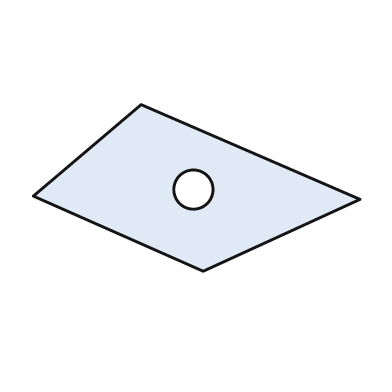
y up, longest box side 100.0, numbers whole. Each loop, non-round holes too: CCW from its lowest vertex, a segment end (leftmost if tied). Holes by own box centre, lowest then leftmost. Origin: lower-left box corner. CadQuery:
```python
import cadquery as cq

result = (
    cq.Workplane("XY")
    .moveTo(52.0, 0.0)
    .lineTo(100.0, 22.0)
    .lineTo(33.0, 51.0)
    .lineTo(0.0, 23.0)
    .close()
    .moveTo(49.0, 25.0)
    .circle(6.0)
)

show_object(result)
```